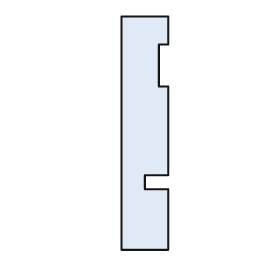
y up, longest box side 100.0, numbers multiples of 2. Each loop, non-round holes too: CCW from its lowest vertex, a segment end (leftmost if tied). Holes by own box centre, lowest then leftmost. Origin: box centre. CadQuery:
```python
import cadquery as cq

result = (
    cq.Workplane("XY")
    .moveTo(-10.0, -50.0)
    .lineTo(10.0, -50.0)
    .lineTo(10.0, -24.0)
    .lineTo(0.0, -24.0)
    .lineTo(0.0, -18.0)
    .lineTo(10.0, -18.0)
    .lineTo(10.0, 20.0)
    .lineTo(6.0, 20.0)
    .lineTo(6.0, 38.0)
    .lineTo(10.0, 38.0)
    .lineTo(10.0, 50.0)
    .lineTo(-10.0, 50.0)
    .close()
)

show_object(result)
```